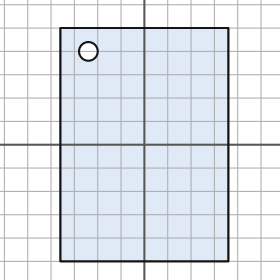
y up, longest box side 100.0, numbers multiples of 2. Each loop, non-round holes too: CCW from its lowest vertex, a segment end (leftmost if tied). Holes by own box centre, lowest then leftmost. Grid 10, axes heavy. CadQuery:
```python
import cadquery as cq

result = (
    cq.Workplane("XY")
    .moveTo(-36.0, -50.0)
    .lineTo(36.0, -50.0)
    .lineTo(36.0, 50.0)
    .lineTo(-36.0, 50.0)
    .close()
    .moveTo(-24.0, 40.0)
    .circle(4.0)
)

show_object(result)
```